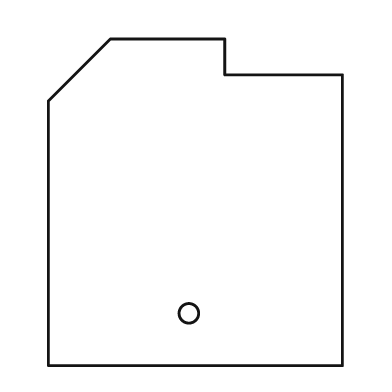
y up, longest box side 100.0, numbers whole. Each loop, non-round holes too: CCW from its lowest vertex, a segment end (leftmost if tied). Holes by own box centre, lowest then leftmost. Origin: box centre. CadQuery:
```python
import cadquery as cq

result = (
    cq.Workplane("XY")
    .moveTo(-45.0, -50.0)
    .lineTo(45.0, -50.0)
    .lineTo(45.0, 39.0)
    .lineTo(9.0, 39.0)
    .lineTo(9.0, 50.0)
    .lineTo(-26.0, 50.0)
    .lineTo(-45.0, 31.0)
    .close()
    .moveTo(-2.0, -34.0)
    .circle(3.0)
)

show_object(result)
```